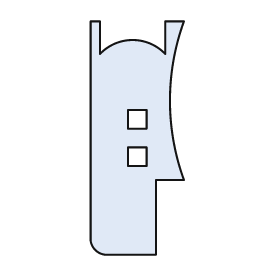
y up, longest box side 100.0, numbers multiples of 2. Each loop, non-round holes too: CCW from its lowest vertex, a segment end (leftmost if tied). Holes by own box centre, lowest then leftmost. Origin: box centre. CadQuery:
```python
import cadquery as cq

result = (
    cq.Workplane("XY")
    .moveTo(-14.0, -50.0)
    .lineTo(8.0, -50.0)
    .lineTo(8.0, -18.0)
    .lineTo(20.0, -18.0)
    .threePointArc((14.0, 16.0), (20.0, 50.0))
    .lineTo(12.0, 50.0)
    .lineTo(12.0, 36.0)
    .threePointArc((-2.0, 42.0), (-16.0, 36.0))
    .lineTo(-16.0, 50.0)
    .lineTo(-20.0, 50.0)
    .lineTo(-20.0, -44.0)
    .threePointArc((-18.0, -48.0), (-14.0, -50.0))
    .close()
    .moveTo(-4.0, -12.0)
    .lineTo(4.0, -12.0)
    .lineTo(4.0, -4.0)
    .lineTo(-4.0, -4.0)
    .close()
    .moveTo(-4.0, 4.0)
    .lineTo(4.0, 4.0)
    .lineTo(4.0, 12.0)
    .lineTo(-4.0, 12.0)
    .close()
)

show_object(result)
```